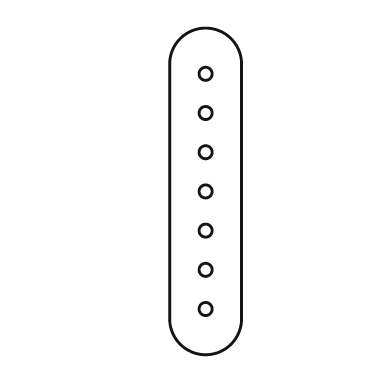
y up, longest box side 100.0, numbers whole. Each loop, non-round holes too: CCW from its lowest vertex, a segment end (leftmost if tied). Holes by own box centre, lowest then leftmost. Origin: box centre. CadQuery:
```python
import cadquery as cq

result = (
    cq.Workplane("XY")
    .moveTo(-11.0, -39.0)
    .threePointArc((0.0, -50.0), (11.0, -39.0))
    .lineTo(11.0, 39.0)
    .threePointArc((0.0, 50.0), (-11.0, 39.0))
    .close()
    .moveTo(0.0, -36.0)
    .circle(2.0)
    .moveTo(0.0, -24.0)
    .circle(2.0)
    .moveTo(0.0, -12.0)
    .circle(2.0)
    .moveTo(0.0, 0.0)
    .circle(2.0)
    .moveTo(0.0, 12.0)
    .circle(2.0)
    .moveTo(0.0, 24.0)
    .circle(2.0)
    .moveTo(0.0, 36.0)
    .circle(2.0)
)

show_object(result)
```